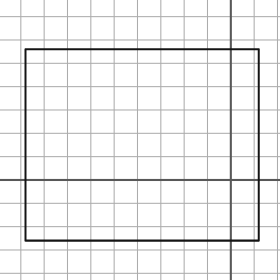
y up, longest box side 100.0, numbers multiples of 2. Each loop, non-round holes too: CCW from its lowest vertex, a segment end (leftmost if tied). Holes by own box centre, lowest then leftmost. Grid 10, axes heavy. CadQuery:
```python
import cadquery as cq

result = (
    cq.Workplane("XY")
    .moveTo(-88.0, -26.0)
    .lineTo(12.0, -26.0)
    .lineTo(12.0, 56.0)
    .lineTo(-88.0, 56.0)
    .close()
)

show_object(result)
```